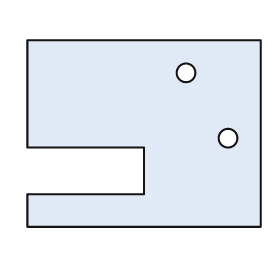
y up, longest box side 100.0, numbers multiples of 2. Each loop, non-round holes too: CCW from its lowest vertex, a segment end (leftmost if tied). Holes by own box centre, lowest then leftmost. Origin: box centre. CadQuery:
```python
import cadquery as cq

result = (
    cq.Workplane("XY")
    .moveTo(-50.0, -40.0)
    .lineTo(50.0, -40.0)
    .lineTo(50.0, 40.0)
    .lineTo(-50.0, 40.0)
    .lineTo(-50.0, -6.0)
    .lineTo(0.0, -6.0)
    .lineTo(0.0, -26.0)
    .lineTo(-50.0, -26.0)
    .close()
    .moveTo(36.0, -2.0)
    .circle(4.0)
    .moveTo(18.0, 26.0)
    .circle(4.0)
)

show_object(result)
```